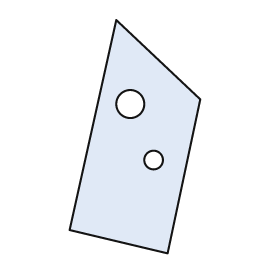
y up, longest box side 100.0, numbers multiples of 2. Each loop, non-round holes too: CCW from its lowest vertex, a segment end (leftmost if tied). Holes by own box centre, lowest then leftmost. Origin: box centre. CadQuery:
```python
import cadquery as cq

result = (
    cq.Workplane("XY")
    .moveTo(14.0, -50.0)
    .lineTo(28.0, 16.0)
    .lineTo(-8.0, 50.0)
    .lineTo(-28.0, -40.0)
    .close()
    .moveTo(8.0, -10.0)
    .circle(4.0)
    .moveTo(-2.0, 14.0)
    .circle(6.0)
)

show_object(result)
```